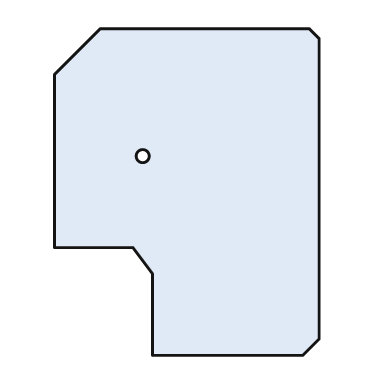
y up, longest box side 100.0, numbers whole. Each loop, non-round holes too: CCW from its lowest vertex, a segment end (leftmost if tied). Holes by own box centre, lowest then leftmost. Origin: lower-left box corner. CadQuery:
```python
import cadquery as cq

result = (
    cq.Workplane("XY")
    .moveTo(30.0, 0.0)
    .lineTo(76.0, 0.0)
    .lineTo(81.0, 5.0)
    .lineTo(81.0, 97.0)
    .lineTo(78.0, 100.0)
    .lineTo(14.0, 100.0)
    .lineTo(0.0, 86.0)
    .lineTo(0.0, 33.0)
    .lineTo(24.0, 33.0)
    .lineTo(30.0, 25.0)
    .close()
    .moveTo(27.0, 61.0)
    .circle(2.0)
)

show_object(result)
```